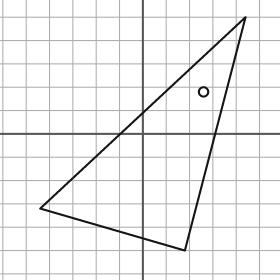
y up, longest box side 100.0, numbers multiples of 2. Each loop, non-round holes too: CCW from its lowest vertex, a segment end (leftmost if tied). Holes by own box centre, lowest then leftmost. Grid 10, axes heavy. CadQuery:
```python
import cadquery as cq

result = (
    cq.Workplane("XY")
    .moveTo(18.0, -50.0)
    .lineTo(44.0, 50.0)
    .lineTo(-44.0, -32.0)
    .close()
    .moveTo(26.0, 18.0)
    .circle(2.0)
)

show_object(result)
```